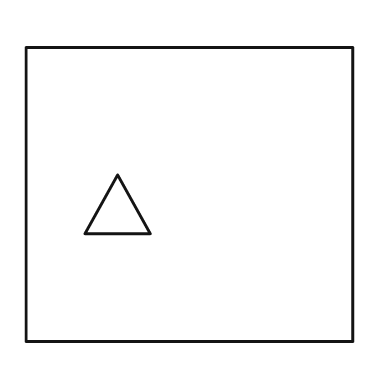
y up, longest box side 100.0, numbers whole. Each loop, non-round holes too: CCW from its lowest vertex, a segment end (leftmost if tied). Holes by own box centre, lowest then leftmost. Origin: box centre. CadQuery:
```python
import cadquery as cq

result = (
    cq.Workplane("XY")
    .moveTo(-50.0, -45.0)
    .lineTo(50.0, -45.0)
    .lineTo(50.0, 45.0)
    .lineTo(-50.0, 45.0)
    .close()
    .moveTo(-32.0, -12.0)
    .lineTo(-12.0, -12.0)
    .lineTo(-22.0, 6.0)
    .close()
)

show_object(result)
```